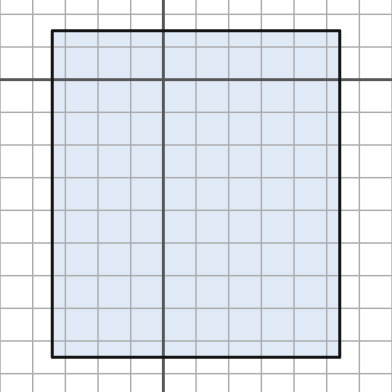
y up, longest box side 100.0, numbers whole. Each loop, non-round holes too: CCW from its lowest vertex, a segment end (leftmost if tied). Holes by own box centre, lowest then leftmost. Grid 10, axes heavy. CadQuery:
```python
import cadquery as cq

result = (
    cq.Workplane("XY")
    .moveTo(-34.0, -85.0)
    .lineTo(54.0, -85.0)
    .lineTo(54.0, 15.0)
    .lineTo(-34.0, 15.0)
    .close()
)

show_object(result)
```